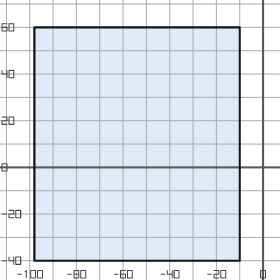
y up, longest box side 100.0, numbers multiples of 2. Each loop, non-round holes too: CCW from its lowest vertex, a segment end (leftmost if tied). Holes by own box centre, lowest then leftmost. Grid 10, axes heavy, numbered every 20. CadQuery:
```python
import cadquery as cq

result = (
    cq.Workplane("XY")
    .moveTo(-98.0, -40.0)
    .lineTo(-10.0, -40.0)
    .lineTo(-10.0, 60.0)
    .lineTo(-98.0, 60.0)
    .close()
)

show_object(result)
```